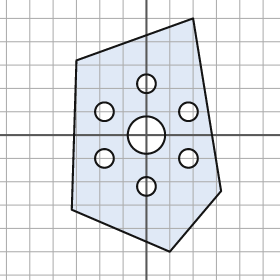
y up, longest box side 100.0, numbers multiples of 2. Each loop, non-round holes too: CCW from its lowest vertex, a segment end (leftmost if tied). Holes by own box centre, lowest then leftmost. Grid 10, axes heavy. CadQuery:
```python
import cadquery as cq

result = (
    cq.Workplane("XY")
    .moveTo(10.0, -50.0)
    .lineTo(32.0, -24.0)
    .lineTo(20.0, 50.0)
    .lineTo(-30.0, 32.0)
    .lineTo(-32.0, -32.0)
    .close()
    .moveTo(0.0, -22.0)
    .circle(4.0)
    .moveTo(-18.0, -10.0)
    .circle(4.0)
    .moveTo(18.0, -10.0)
    .circle(4.0)
    .moveTo(0.0, 0.0)
    .circle(8.0)
    .moveTo(-18.0, 10.0)
    .circle(4.0)
    .moveTo(18.0, 10.0)
    .circle(4.0)
    .moveTo(0.0, 22.0)
    .circle(4.0)
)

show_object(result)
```